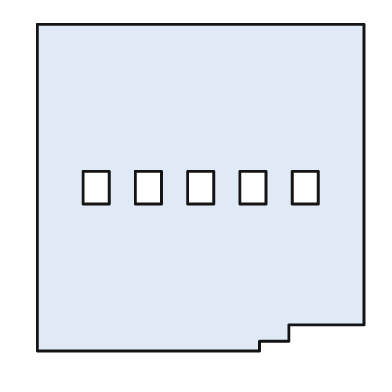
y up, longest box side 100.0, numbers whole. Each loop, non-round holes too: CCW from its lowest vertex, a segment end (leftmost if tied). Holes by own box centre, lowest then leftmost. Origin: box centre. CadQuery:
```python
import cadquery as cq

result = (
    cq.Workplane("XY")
    .moveTo(-50.0, -50.0)
    .lineTo(18.0, -50.0)
    .lineTo(18.0, -47.0)
    .lineTo(27.0, -47.0)
    .lineTo(27.0, -42.0)
    .lineTo(50.0, -42.0)
    .lineTo(50.0, 50.0)
    .lineTo(-50.0, 50.0)
    .close()
    .moveTo(-36.0, -5.0)
    .lineTo(-28.0, -5.0)
    .lineTo(-28.0, 5.0)
    .lineTo(-36.0, 5.0)
    .close()
    .moveTo(-20.0, -5.0)
    .lineTo(-12.0, -5.0)
    .lineTo(-12.0, 5.0)
    .lineTo(-20.0, 5.0)
    .close()
    .moveTo(-4.0, -5.0)
    .lineTo(4.0, -5.0)
    .lineTo(4.0, 5.0)
    .lineTo(-4.0, 5.0)
    .close()
    .moveTo(12.0, -5.0)
    .lineTo(20.0, -5.0)
    .lineTo(20.0, 5.0)
    .lineTo(12.0, 5.0)
    .close()
    .moveTo(28.0, -5.0)
    .lineTo(36.0, -5.0)
    .lineTo(36.0, 5.0)
    .lineTo(28.0, 5.0)
    .close()
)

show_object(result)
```